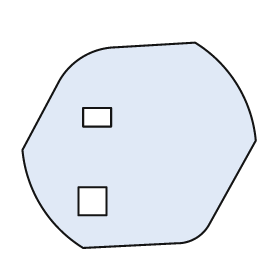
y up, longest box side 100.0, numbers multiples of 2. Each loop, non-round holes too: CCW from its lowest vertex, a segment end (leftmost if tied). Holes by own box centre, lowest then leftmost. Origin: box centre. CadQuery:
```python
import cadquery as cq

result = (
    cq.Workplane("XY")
    .moveTo(-24.0, -44.0)
    .lineTo(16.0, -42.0)
    .threePointArc((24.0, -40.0), (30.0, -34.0))
    .lineTo(50.0, 2.0)
    .threePointArc((42.0, 26.0), (24.0, 44.0))
    .lineTo(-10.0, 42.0)
    .threePointArc((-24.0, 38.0), (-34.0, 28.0))
    .lineTo(-50.0, -2.0)
    .threePointArc((-42.0, -26.0), (-24.0, -44.0))
    .close()
    .moveTo(-26.0, -30.0)
    .lineTo(-14.0, -30.0)
    .lineTo(-14.0, -18.0)
    .lineTo(-26.0, -18.0)
    .close()
    .moveTo(-24.0, 8.0)
    .lineTo(-12.0, 8.0)
    .lineTo(-12.0, 16.0)
    .lineTo(-24.0, 16.0)
    .close()
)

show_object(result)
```